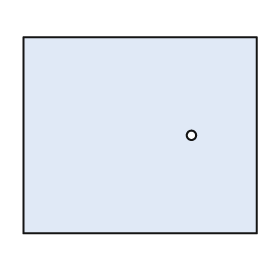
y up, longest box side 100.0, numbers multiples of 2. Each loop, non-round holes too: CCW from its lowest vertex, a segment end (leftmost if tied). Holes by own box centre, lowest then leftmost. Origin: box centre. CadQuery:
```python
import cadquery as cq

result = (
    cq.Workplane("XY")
    .moveTo(-50.0, -42.0)
    .lineTo(50.0, -42.0)
    .lineTo(50.0, 42.0)
    .lineTo(-50.0, 42.0)
    .close()
    .moveTo(22.0, 0.0)
    .circle(2.0)
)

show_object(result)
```